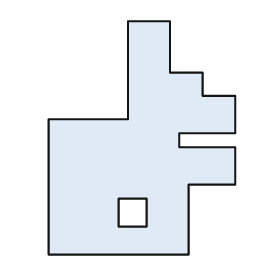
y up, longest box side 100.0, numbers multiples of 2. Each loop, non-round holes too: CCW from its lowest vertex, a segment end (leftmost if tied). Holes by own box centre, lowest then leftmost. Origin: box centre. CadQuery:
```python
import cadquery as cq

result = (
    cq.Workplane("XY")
    .moveTo(-40.0, -50.0)
    .lineTo(20.0, -50.0)
    .lineTo(20.0, -20.0)
    .lineTo(40.0, -20.0)
    .lineTo(40.0, -4.0)
    .lineTo(16.0, -4.0)
    .lineTo(16.0, 2.0)
    .lineTo(40.0, 2.0)
    .lineTo(40.0, 18.0)
    .lineTo(26.0, 18.0)
    .lineTo(26.0, 28.0)
    .lineTo(12.0, 28.0)
    .lineTo(12.0, 50.0)
    .lineTo(-6.0, 50.0)
    .lineTo(-6.0, 8.0)
    .lineTo(-40.0, 8.0)
    .close()
    .moveTo(-10.0, -38.0)
    .lineTo(2.0, -38.0)
    .lineTo(2.0, -26.0)
    .lineTo(-10.0, -26.0)
    .close()
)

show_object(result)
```